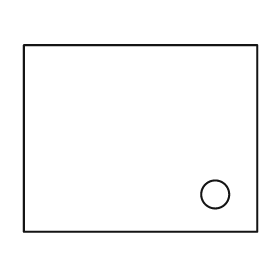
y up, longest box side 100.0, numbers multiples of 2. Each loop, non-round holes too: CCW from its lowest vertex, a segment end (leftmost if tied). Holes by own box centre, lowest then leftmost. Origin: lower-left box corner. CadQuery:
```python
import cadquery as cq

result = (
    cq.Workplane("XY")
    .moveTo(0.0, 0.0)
    .lineTo(100.0, 0.0)
    .lineTo(100.0, 80.0)
    .lineTo(0.0, 80.0)
    .close()
    .moveTo(82.0, 16.0)
    .circle(6.0)
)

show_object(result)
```